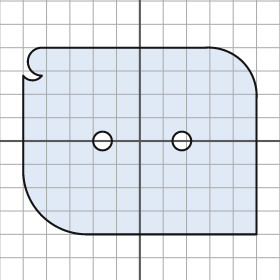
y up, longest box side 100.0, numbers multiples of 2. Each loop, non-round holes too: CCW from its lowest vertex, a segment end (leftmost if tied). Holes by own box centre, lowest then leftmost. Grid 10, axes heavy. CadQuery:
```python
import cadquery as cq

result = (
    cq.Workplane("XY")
    .moveTo(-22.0, -40.0)
    .lineTo(50.0, -40.0)
    .lineTo(50.0, 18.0)
    .threePointArc((44.0, 34.0), (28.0, 40.0))
    .lineTo(-42.0, 40.0)
    .threePointArc((-48.0, 34.0), (-42.0, 28.0))
    .threePointArc((-46.0, 26.0), (-50.0, 28.0))
    .lineTo(-50.0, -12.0)
    .threePointArc((-42.0, -32.0), (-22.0, -40.0))
    .close()
    .moveTo(-16.0, 0.0)
    .circle(4.0)
    .moveTo(18.0, 0.0)
    .circle(4.0)
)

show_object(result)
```